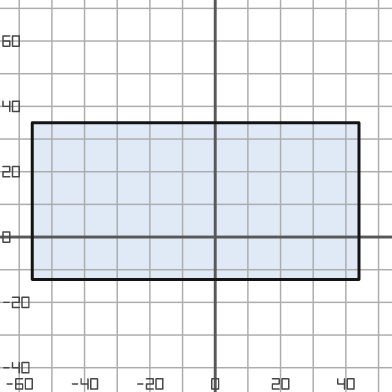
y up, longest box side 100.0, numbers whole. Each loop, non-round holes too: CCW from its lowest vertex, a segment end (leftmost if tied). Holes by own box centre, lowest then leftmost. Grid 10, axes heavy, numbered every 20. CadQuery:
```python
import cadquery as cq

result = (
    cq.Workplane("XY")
    .moveTo(-56.0, -13.0)
    .lineTo(44.0, -13.0)
    .lineTo(44.0, 35.0)
    .lineTo(-56.0, 35.0)
    .close()
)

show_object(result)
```